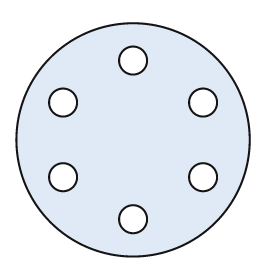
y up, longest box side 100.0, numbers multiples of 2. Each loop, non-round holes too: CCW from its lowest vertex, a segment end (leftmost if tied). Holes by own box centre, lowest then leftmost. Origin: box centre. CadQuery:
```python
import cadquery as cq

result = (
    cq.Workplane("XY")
    .moveTo(0.0, 0.0)
    .circle(50.0)
    .moveTo(0.0, -34.0)
    .circle(6.0)
    .moveTo(-30.0, -16.0)
    .circle(6.0)
    .moveTo(30.0, -16.0)
    .circle(6.0)
    .moveTo(-30.0, 16.0)
    .circle(6.0)
    .moveTo(30.0, 16.0)
    .circle(6.0)
    .moveTo(0.0, 34.0)
    .circle(6.0)
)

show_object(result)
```